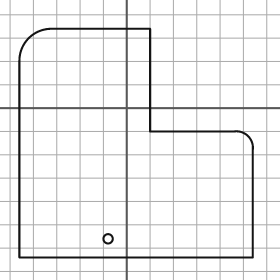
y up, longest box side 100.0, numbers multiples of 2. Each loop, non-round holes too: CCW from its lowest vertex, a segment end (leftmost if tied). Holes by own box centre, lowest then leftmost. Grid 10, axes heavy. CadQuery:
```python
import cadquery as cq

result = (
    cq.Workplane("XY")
    .moveTo(-46.0, -64.0)
    .lineTo(54.0, -64.0)
    .lineTo(54.0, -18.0)
    .threePointArc((52.0, -12.0), (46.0, -10.0))
    .lineTo(10.0, -10.0)
    .lineTo(10.0, 34.0)
    .lineTo(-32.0, 34.0)
    .threePointArc((-42.0, 30.0), (-46.0, 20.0))
    .close()
    .moveTo(-8.0, -56.0)
    .circle(2.0)
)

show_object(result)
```